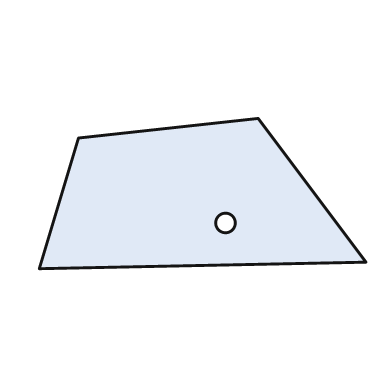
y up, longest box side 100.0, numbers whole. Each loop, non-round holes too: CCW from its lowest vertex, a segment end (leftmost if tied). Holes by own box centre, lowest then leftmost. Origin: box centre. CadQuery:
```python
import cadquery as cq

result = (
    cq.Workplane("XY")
    .moveTo(-50.0, -23.0)
    .lineTo(50.0, -21.0)
    .lineTo(17.0, 23.0)
    .lineTo(-38.0, 17.0)
    .close()
    .moveTo(7.0, -9.0)
    .circle(3.0)
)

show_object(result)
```